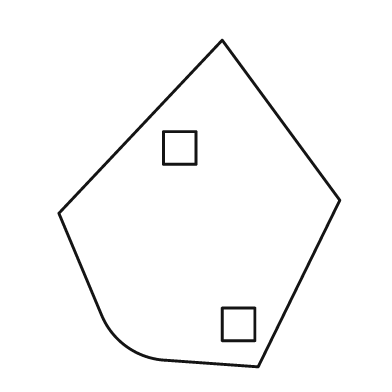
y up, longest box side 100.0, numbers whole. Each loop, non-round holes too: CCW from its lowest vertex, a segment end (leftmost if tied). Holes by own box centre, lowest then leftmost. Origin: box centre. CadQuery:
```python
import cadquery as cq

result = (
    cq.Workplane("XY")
    .moveTo(18.0, -50.0)
    .lineTo(43.0, 1.0)
    .lineTo(7.0, 50.0)
    .lineTo(-43.0, -3.0)
    .lineTo(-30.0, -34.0)
    .threePointArc((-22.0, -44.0), (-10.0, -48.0))
    .close()
    .moveTo(7.0, -42.0)
    .lineTo(17.0, -42.0)
    .lineTo(17.0, -32.0)
    .lineTo(7.0, -32.0)
    .close()
    .moveTo(-11.0, 12.0)
    .lineTo(-1.0, 12.0)
    .lineTo(-1.0, 22.0)
    .lineTo(-11.0, 22.0)
    .close()
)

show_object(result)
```